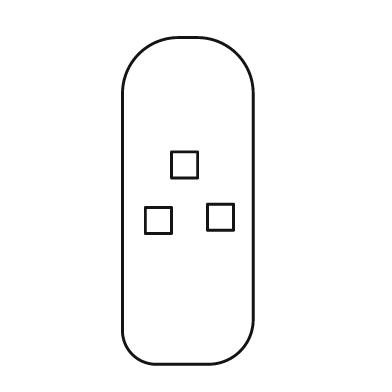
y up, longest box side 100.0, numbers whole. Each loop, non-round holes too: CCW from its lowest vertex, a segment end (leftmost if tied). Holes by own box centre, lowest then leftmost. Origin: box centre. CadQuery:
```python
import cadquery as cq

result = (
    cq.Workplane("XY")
    .moveTo(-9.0, -50.0)
    .lineTo(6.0, -50.0)
    .threePointArc((16.0, -46.0), (20.0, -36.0))
    .lineTo(20.0, 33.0)
    .threePointArc((15.0, 45.0), (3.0, 50.0))
    .lineTo(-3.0, 50.0)
    .threePointArc((-15.0, 45.0), (-20.0, 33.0))
    .lineTo(-20.0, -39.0)
    .threePointArc((-17.0, -47.0), (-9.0, -50.0))
    .close()
    .moveTo(-13.0, -10.0)
    .lineTo(-5.0, -10.0)
    .lineTo(-5.0, -2.0)
    .lineTo(-13.0, -2.0)
    .close()
    .moveTo(6.0, -9.0)
    .lineTo(14.0, -9.0)
    .lineTo(14.0, -1.0)
    .lineTo(6.0, -1.0)
    .close()
    .moveTo(-5.0, 7.0)
    .lineTo(3.0, 7.0)
    .lineTo(3.0, 15.0)
    .lineTo(-5.0, 15.0)
    .close()
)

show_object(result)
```